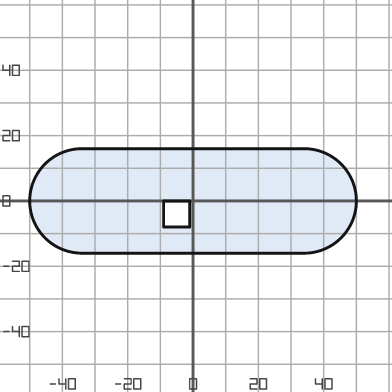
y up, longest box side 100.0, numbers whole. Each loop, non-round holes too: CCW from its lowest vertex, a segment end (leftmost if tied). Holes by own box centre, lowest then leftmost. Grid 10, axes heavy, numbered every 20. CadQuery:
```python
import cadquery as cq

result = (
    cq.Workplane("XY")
    .moveTo(-34.0, -16.0)
    .lineTo(34.0, -16.0)
    .threePointArc((50.0, 0.0), (34.0, 16.0))
    .lineTo(-34.0, 16.0)
    .threePointArc((-50.0, 0.0), (-34.0, -16.0))
    .close()
    .moveTo(-9.0, -8.0)
    .lineTo(-1.0, -8.0)
    .lineTo(-1.0, 0.0)
    .lineTo(-9.0, 0.0)
    .close()
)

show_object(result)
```